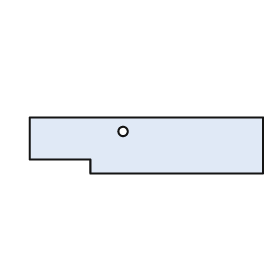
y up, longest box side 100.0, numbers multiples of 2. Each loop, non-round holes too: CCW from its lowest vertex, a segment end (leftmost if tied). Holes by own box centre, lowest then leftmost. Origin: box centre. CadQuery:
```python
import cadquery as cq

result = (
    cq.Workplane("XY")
    .moveTo(-24.0, -12.0)
    .lineTo(50.0, -12.0)
    .lineTo(50.0, 12.0)
    .lineTo(-50.0, 12.0)
    .lineTo(-50.0, -6.0)
    .lineTo(-24.0, -6.0)
    .close()
    .moveTo(-10.0, 6.0)
    .circle(2.0)
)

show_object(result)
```